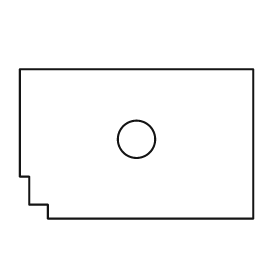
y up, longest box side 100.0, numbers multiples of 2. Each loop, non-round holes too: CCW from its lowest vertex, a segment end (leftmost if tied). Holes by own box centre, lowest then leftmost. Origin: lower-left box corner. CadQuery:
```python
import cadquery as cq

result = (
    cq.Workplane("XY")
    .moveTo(12.0, 0.0)
    .lineTo(100.0, 0.0)
    .lineTo(100.0, 64.0)
    .lineTo(0.0, 64.0)
    .lineTo(0.0, 18.0)
    .lineTo(4.0, 18.0)
    .lineTo(4.0, 6.0)
    .lineTo(12.0, 6.0)
    .close()
    .moveTo(50.0, 34.0)
    .circle(8.0)
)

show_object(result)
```